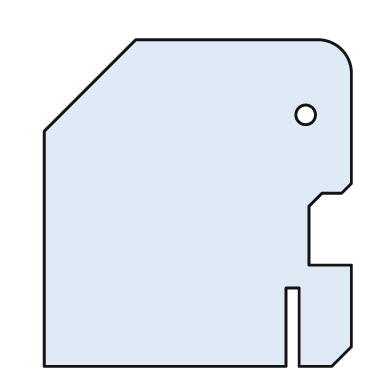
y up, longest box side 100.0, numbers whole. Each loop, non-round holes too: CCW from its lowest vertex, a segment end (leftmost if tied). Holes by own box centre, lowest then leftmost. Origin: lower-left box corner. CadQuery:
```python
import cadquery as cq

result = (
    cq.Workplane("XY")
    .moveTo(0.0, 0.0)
    .lineTo(74.0, 0.0)
    .lineTo(74.0, 24.0)
    .lineTo(78.0, 24.0)
    .lineTo(78.0, 0.0)
    .lineTo(88.0, 0.0)
    .lineTo(94.0, 6.0)
    .lineTo(94.0, 31.0)
    .lineTo(81.0, 31.0)
    .lineTo(81.0, 49.0)
    .lineTo(85.0, 53.0)
    .lineTo(91.0, 53.0)
    .lineTo(94.0, 56.0)
    .lineTo(94.0, 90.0)
    .threePointArc((91.0, 97.0), (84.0, 100.0))
    .lineTo(28.0, 100.0)
    .lineTo(0.0, 72.0)
    .close()
    .moveTo(80.0, 77.0)
    .circle(3.0)
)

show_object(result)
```